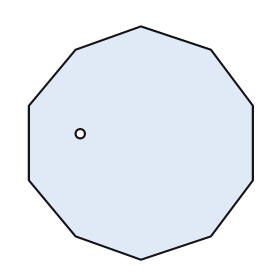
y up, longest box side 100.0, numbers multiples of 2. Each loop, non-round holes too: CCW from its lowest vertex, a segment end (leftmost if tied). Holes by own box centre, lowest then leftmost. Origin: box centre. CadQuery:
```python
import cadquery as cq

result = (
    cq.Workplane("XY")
    .moveTo(0.0, -50.0)
    .lineTo(30.0, -40.0)
    .lineTo(48.0, -16.0)
    .lineTo(48.0, 16.0)
    .lineTo(30.0, 40.0)
    .lineTo(0.0, 50.0)
    .lineTo(-28.0, 40.0)
    .lineTo(-48.0, 16.0)
    .lineTo(-48.0, -16.0)
    .lineTo(-28.0, -40.0)
    .close()
    .moveTo(-26.0, 4.0)
    .circle(2.0)
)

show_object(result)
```